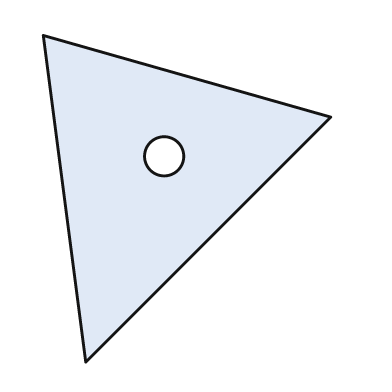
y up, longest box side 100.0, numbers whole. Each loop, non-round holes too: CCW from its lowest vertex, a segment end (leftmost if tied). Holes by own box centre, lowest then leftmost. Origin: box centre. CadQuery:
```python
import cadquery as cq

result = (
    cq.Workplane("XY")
    .moveTo(-31.0, -50.0)
    .lineTo(44.0, 25.0)
    .lineTo(-44.0, 50.0)
    .close()
    .moveTo(-7.0, 13.0)
    .circle(6.0)
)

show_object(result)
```